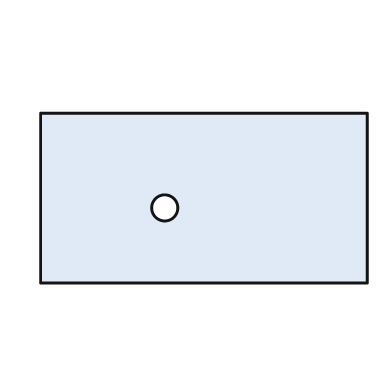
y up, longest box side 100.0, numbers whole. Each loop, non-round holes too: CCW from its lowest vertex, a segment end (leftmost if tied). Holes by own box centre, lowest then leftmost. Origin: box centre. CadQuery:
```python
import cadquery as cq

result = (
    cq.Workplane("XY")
    .moveTo(-50.0, -26.0)
    .lineTo(50.0, -26.0)
    .lineTo(50.0, 26.0)
    .lineTo(-50.0, 26.0)
    .close()
    .moveTo(-12.0, -3.0)
    .circle(4.0)
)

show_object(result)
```